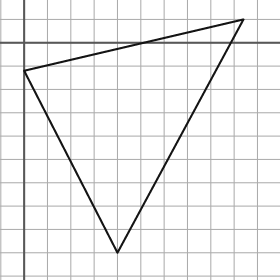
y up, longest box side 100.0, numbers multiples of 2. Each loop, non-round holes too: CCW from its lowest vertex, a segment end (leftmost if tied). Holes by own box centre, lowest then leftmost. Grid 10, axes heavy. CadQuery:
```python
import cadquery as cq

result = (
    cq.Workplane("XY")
    .moveTo(40.0, -90.0)
    .lineTo(94.0, 10.0)
    .lineTo(0.0, -12.0)
    .close()
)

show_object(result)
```